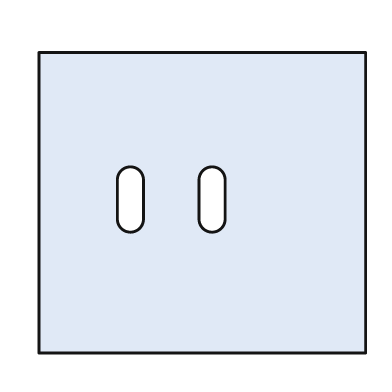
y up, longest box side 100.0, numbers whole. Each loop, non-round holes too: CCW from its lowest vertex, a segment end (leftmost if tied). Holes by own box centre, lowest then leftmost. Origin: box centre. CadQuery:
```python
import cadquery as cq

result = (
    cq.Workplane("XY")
    .moveTo(-50.0, -46.0)
    .lineTo(50.0, -46.0)
    .lineTo(50.0, 46.0)
    .lineTo(-50.0, 46.0)
    .close()
    .moveTo(-26.0, -5.0)
    .threePointArc((-22.0, -9.0), (-18.0, -5.0))
    .lineTo(-18.0, 7.0)
    .threePointArc((-22.0, 11.0), (-26.0, 7.0))
    .close()
    .moveTo(-1.0, -5.0)
    .threePointArc((3.0, -9.0), (7.0, -5.0))
    .lineTo(7.0, 7.0)
    .threePointArc((3.0, 11.0), (-1.0, 7.0))
    .close()
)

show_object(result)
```